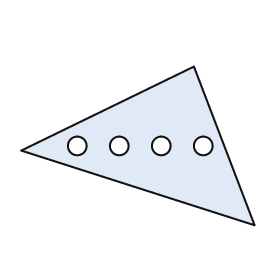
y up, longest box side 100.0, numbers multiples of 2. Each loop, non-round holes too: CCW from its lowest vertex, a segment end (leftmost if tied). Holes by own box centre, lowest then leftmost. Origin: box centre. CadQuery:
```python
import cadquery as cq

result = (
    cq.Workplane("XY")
    .moveTo(50.0, -34.0)
    .lineTo(24.0, 34.0)
    .lineTo(-50.0, -2.0)
    .close()
    .moveTo(-26.0, 0.0)
    .circle(4.0)
    .moveTo(-8.0, 0.0)
    .circle(4.0)
    .moveTo(10.0, 0.0)
    .circle(4.0)
    .moveTo(28.0, 0.0)
    .circle(4.0)
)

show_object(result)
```